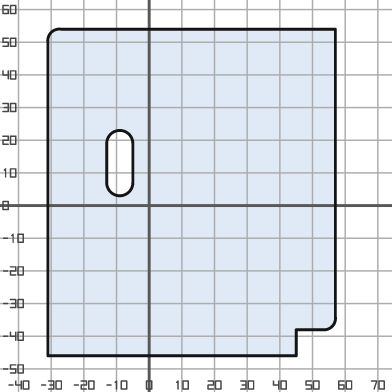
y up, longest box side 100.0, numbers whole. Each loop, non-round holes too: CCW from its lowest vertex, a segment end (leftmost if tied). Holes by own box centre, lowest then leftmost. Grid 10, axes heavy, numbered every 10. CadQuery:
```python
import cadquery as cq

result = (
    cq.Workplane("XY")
    .moveTo(-31.0, -46.0)
    .lineTo(45.0, -46.0)
    .lineTo(45.0, -38.0)
    .lineTo(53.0, -38.0)
    .threePointArc((56.0, -37.0), (57.0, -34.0))
    .lineTo(57.0, 54.0)
    .lineTo(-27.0, 54.0)
    .threePointArc((-30.0, 53.0), (-31.0, 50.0))
    .close()
    .moveTo(-13.0, 7.0)
    .threePointArc((-9.0, 3.0), (-5.0, 7.0))
    .lineTo(-5.0, 19.0)
    .threePointArc((-9.0, 23.0), (-13.0, 19.0))
    .close()
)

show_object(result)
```